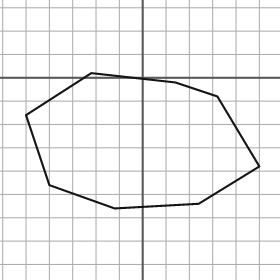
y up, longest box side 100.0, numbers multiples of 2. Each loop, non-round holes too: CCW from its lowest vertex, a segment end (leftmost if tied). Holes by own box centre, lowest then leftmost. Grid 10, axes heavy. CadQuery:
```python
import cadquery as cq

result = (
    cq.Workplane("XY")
    .moveTo(-12.0, -56.0)
    .lineTo(24.0, -54.0)
    .lineTo(50.0, -38.0)
    .lineTo(32.0, -8.0)
    .lineTo(14.0, -2.0)
    .lineTo(-22.0, 2.0)
    .lineTo(-50.0, -16.0)
    .lineTo(-40.0, -46.0)
    .close()
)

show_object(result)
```